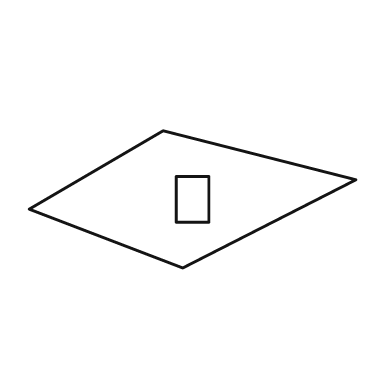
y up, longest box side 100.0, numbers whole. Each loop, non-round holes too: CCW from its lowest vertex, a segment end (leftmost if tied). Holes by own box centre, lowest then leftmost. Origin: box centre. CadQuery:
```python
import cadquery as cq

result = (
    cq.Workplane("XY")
    .moveTo(-3.0, -21.0)
    .lineTo(50.0, 6.0)
    .lineTo(-9.0, 21.0)
    .lineTo(-50.0, -3.0)
    .close()
    .moveTo(-5.0, -7.0)
    .lineTo(5.0, -7.0)
    .lineTo(5.0, 7.0)
    .lineTo(-5.0, 7.0)
    .close()
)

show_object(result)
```